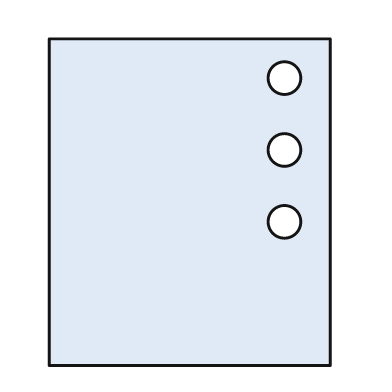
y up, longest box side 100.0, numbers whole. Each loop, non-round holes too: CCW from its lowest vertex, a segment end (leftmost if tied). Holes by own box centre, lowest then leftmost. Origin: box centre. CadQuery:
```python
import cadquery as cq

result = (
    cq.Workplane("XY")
    .moveTo(-43.0, -50.0)
    .lineTo(43.0, -50.0)
    .lineTo(43.0, 50.0)
    .lineTo(-43.0, 50.0)
    .close()
    .moveTo(29.0, -6.0)
    .circle(5.0)
    .moveTo(29.0, 16.0)
    .circle(5.0)
    .moveTo(29.0, 38.0)
    .circle(5.0)
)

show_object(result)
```